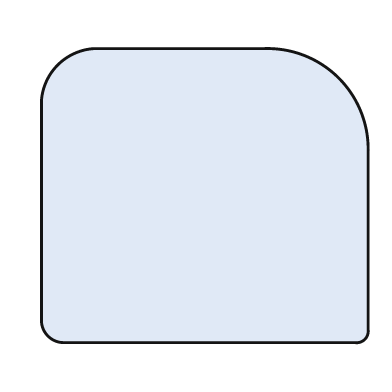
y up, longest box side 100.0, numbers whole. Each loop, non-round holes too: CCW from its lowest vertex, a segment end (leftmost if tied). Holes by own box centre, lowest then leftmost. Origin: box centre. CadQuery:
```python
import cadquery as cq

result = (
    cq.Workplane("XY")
    .moveTo(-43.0, -45.0)
    .lineTo(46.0, -45.0)
    .threePointArc((49.0, -44.0), (50.0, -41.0))
    .lineTo(50.0, 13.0)
    .threePointArc((41.0, 36.0), (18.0, 45.0))
    .lineTo(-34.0, 45.0)
    .threePointArc((-45.0, 40.0), (-50.0, 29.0))
    .lineTo(-50.0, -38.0)
    .threePointArc((-48.0, -43.0), (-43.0, -45.0))
    .close()
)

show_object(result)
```